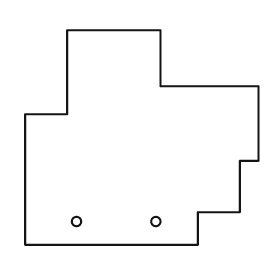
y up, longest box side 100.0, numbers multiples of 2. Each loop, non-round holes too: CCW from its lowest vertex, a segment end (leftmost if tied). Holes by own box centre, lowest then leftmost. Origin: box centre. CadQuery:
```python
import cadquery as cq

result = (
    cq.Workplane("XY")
    .moveTo(-50.0, -46.0)
    .lineTo(24.0, -46.0)
    .lineTo(24.0, -32.0)
    .lineTo(42.0, -32.0)
    .lineTo(42.0, -10.0)
    .lineTo(50.0, -10.0)
    .lineTo(50.0, 22.0)
    .lineTo(8.0, 22.0)
    .lineTo(8.0, 46.0)
    .lineTo(-32.0, 46.0)
    .lineTo(-32.0, 10.0)
    .lineTo(-50.0, 10.0)
    .close()
    .moveTo(-28.0, -36.0)
    .circle(2.0)
    .moveTo(6.0, -36.0)
    .circle(2.0)
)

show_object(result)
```